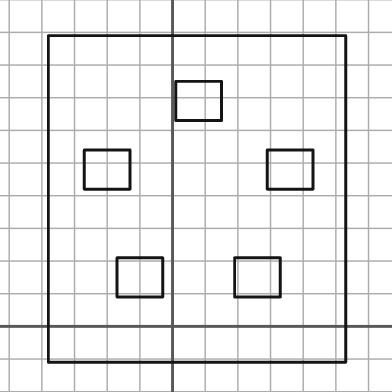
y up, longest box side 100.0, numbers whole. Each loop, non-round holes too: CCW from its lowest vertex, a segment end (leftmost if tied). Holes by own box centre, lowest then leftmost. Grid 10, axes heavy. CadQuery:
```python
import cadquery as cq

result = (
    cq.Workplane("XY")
    .moveTo(-38.0, -11.0)
    .lineTo(53.0, -11.0)
    .lineTo(53.0, 89.0)
    .lineTo(-38.0, 89.0)
    .close()
    .moveTo(-17.0, 9.0)
    .lineTo(-3.0, 9.0)
    .lineTo(-3.0, 21.0)
    .lineTo(-17.0, 21.0)
    .close()
    .moveTo(19.0, 9.0)
    .lineTo(33.0, 9.0)
    .lineTo(33.0, 21.0)
    .lineTo(19.0, 21.0)
    .close()
    .moveTo(-27.0, 42.0)
    .lineTo(-13.0, 42.0)
    .lineTo(-13.0, 54.0)
    .lineTo(-27.0, 54.0)
    .close()
    .moveTo(29.0, 42.0)
    .lineTo(43.0, 42.0)
    .lineTo(43.0, 54.0)
    .lineTo(29.0, 54.0)
    .close()
    .moveTo(1.0, 63.0)
    .lineTo(15.0, 63.0)
    .lineTo(15.0, 75.0)
    .lineTo(1.0, 75.0)
    .close()
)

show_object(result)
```